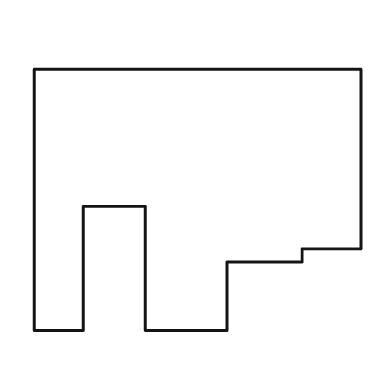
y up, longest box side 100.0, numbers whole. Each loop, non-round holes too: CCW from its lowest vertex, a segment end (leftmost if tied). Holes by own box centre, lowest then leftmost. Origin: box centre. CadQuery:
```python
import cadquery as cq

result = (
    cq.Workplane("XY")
    .moveTo(-50.0, -40.0)
    .lineTo(-35.0, -40.0)
    .lineTo(-35.0, -2.0)
    .lineTo(-16.0, -2.0)
    .lineTo(-16.0, -40.0)
    .lineTo(9.0, -40.0)
    .lineTo(9.0, -19.0)
    .lineTo(32.0, -19.0)
    .lineTo(32.0, -15.0)
    .lineTo(50.0, -15.0)
    .lineTo(50.0, 40.0)
    .lineTo(-50.0, 40.0)
    .close()
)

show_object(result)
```